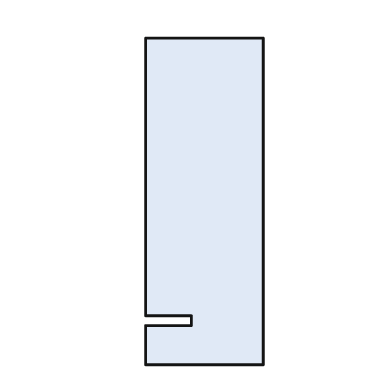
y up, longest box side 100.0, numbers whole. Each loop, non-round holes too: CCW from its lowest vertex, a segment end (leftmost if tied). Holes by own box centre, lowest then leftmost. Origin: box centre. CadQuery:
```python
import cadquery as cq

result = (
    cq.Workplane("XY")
    .moveTo(-18.0, -50.0)
    .lineTo(18.0, -50.0)
    .lineTo(18.0, 50.0)
    .lineTo(-18.0, 50.0)
    .lineTo(-18.0, -35.0)
    .lineTo(-4.0, -35.0)
    .lineTo(-4.0, -38.0)
    .lineTo(-18.0, -38.0)
    .close()
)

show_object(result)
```